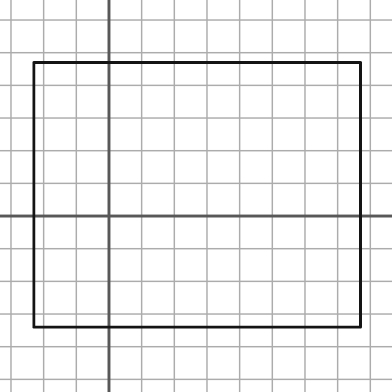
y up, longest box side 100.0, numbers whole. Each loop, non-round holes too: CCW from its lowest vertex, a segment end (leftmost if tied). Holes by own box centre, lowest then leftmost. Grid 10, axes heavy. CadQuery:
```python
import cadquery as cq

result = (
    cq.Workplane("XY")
    .moveTo(-23.0, -34.0)
    .lineTo(77.0, -34.0)
    .lineTo(77.0, 47.0)
    .lineTo(-23.0, 47.0)
    .close()
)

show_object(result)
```